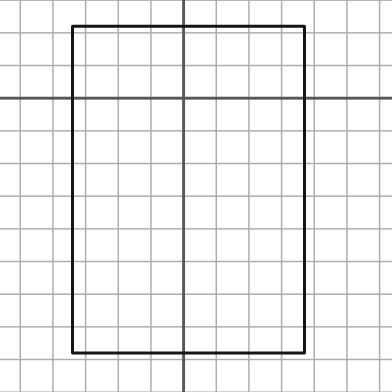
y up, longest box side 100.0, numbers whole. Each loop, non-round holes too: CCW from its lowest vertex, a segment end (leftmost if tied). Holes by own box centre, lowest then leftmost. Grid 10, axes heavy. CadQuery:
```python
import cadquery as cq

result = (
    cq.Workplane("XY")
    .moveTo(-34.0, -78.0)
    .lineTo(37.0, -78.0)
    .lineTo(37.0, 22.0)
    .lineTo(-34.0, 22.0)
    .close()
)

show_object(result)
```